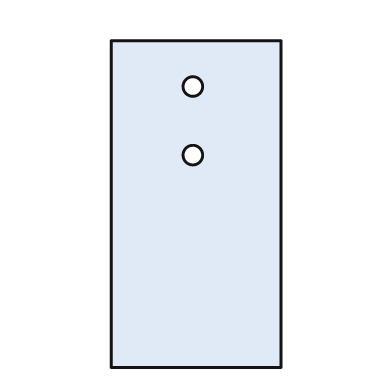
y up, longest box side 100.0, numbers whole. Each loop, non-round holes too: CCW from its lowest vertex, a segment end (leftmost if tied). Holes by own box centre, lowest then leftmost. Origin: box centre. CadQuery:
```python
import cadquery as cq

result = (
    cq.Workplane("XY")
    .moveTo(-26.0, -50.0)
    .lineTo(26.0, -50.0)
    .lineTo(26.0, 50.0)
    .lineTo(-26.0, 50.0)
    .close()
    .moveTo(-1.0, 15.0)
    .circle(3.0)
    .moveTo(-1.0, 36.0)
    .circle(3.0)
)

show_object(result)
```